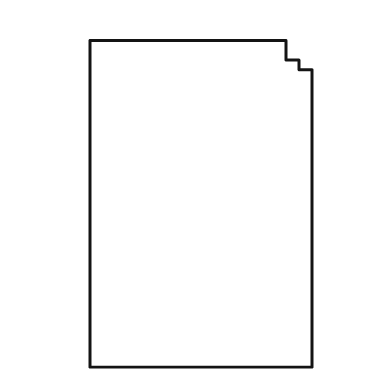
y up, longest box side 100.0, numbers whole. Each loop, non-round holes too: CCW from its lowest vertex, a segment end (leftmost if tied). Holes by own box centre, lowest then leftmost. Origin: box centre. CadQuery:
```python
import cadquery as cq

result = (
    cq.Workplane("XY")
    .moveTo(-34.0, -50.0)
    .lineTo(34.0, -50.0)
    .lineTo(34.0, 41.0)
    .lineTo(30.0, 41.0)
    .lineTo(30.0, 44.0)
    .lineTo(26.0, 44.0)
    .lineTo(26.0, 50.0)
    .lineTo(-34.0, 50.0)
    .close()
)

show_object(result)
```